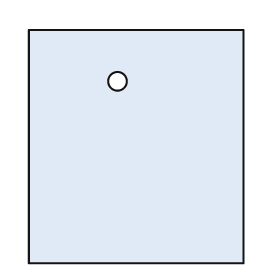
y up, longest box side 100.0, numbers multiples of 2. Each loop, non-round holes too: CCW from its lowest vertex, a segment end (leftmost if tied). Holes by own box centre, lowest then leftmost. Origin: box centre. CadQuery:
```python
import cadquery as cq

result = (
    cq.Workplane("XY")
    .moveTo(-46.0, -50.0)
    .lineTo(46.0, -50.0)
    .lineTo(46.0, 50.0)
    .lineTo(-46.0, 50.0)
    .close()
    .moveTo(-8.0, 28.0)
    .circle(4.0)
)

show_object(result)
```